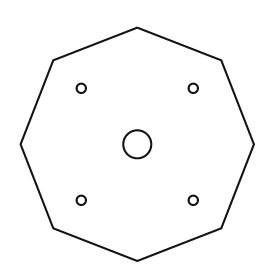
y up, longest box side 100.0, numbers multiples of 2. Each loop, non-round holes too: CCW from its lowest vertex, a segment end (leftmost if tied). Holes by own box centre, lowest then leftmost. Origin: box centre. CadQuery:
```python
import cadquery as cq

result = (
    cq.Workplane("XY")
    .moveTo(0.0, -50.0)
    .lineTo(36.0, -36.0)
    .lineTo(50.0, 0.0)
    .lineTo(36.0, 36.0)
    .lineTo(0.0, 50.0)
    .lineTo(-36.0, 36.0)
    .lineTo(-50.0, 0.0)
    .lineTo(-36.0, -36.0)
    .close()
    .moveTo(-24.0, -24.0)
    .circle(2.0)
    .moveTo(24.0, -24.0)
    .circle(2.0)
    .moveTo(0.0, 0.0)
    .circle(6.0)
    .moveTo(-24.0, 24.0)
    .circle(2.0)
    .moveTo(24.0, 24.0)
    .circle(2.0)
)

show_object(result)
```